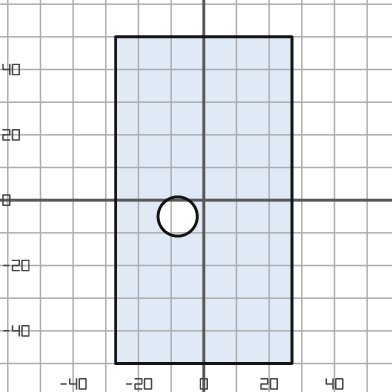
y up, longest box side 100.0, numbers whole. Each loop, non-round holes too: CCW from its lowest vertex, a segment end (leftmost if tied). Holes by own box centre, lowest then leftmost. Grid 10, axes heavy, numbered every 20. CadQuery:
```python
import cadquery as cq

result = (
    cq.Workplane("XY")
    .moveTo(-27.0, -50.0)
    .lineTo(27.0, -50.0)
    .lineTo(27.0, 50.0)
    .lineTo(-27.0, 50.0)
    .close()
    .moveTo(-8.0, -5.0)
    .circle(6.0)
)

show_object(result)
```